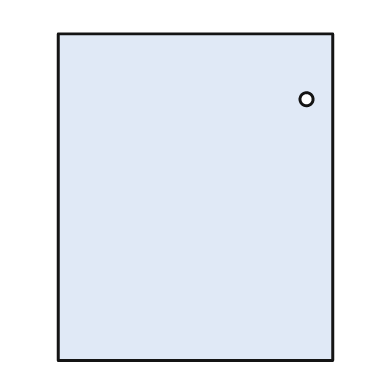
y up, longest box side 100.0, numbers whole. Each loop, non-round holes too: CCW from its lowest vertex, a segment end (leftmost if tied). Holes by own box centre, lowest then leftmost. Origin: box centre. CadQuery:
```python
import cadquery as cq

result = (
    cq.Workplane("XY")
    .moveTo(-42.0, -50.0)
    .lineTo(42.0, -50.0)
    .lineTo(42.0, 50.0)
    .lineTo(-42.0, 50.0)
    .close()
    .moveTo(34.0, 30.0)
    .circle(2.0)
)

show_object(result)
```